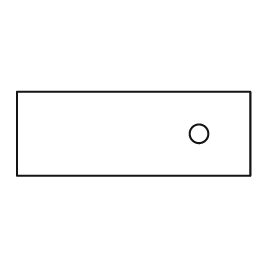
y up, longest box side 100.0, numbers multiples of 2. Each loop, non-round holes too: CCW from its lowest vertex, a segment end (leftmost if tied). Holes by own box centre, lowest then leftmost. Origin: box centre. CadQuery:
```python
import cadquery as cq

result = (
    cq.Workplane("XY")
    .moveTo(-50.0, -18.0)
    .lineTo(50.0, -18.0)
    .lineTo(50.0, 18.0)
    .lineTo(-50.0, 18.0)
    .close()
    .moveTo(28.0, 0.0)
    .circle(4.0)
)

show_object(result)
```